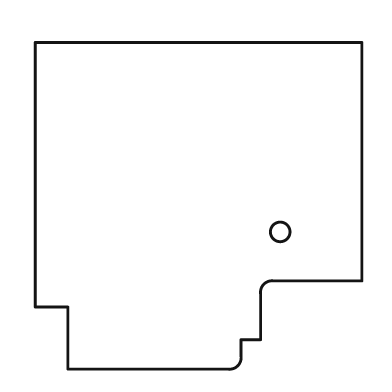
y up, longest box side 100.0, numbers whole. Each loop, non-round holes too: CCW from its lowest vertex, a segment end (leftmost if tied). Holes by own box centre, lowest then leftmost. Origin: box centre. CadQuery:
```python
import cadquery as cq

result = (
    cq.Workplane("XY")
    .moveTo(-40.0, -50.0)
    .lineTo(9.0, -50.0)
    .threePointArc((12.0, -49.0), (13.0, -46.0))
    .lineTo(13.0, -41.0)
    .lineTo(19.0, -41.0)
    .lineTo(19.0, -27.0)
    .threePointArc((20.0, -24.0), (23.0, -23.0))
    .lineTo(50.0, -23.0)
    .lineTo(50.0, 50.0)
    .lineTo(-50.0, 50.0)
    .lineTo(-50.0, -31.0)
    .lineTo(-40.0, -31.0)
    .close()
    .moveTo(25.0, -8.0)
    .circle(3.0)
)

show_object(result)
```